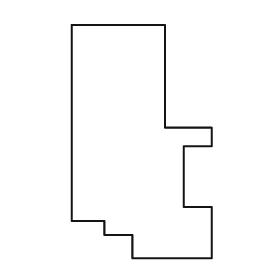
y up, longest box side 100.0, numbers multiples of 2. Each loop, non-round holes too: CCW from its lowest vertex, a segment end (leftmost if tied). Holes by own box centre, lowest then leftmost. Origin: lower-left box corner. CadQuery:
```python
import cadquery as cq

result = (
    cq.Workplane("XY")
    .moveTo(26.0, 0.0)
    .lineTo(60.0, 0.0)
    .lineTo(60.0, 22.0)
    .lineTo(48.0, 22.0)
    .lineTo(48.0, 48.0)
    .lineTo(60.0, 48.0)
    .lineTo(60.0, 56.0)
    .lineTo(40.0, 56.0)
    .lineTo(40.0, 100.0)
    .lineTo(0.0, 100.0)
    .lineTo(0.0, 16.0)
    .lineTo(14.0, 16.0)
    .lineTo(14.0, 10.0)
    .lineTo(26.0, 10.0)
    .close()
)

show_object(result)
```